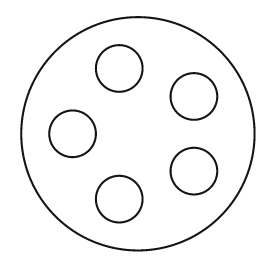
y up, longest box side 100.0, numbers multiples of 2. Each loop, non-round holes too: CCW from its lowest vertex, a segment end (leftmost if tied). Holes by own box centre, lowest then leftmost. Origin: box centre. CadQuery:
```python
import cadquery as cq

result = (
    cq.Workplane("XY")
    .moveTo(0.0, 0.0)
    .circle(50.0)
    .moveTo(-8.0, -28.0)
    .circle(10.0)
    .moveTo(24.0, -16.0)
    .circle(10.0)
    .moveTo(-28.0, 0.0)
    .circle(10.0)
    .moveTo(24.0, 16.0)
    .circle(10.0)
    .moveTo(-8.0, 28.0)
    .circle(10.0)
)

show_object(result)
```